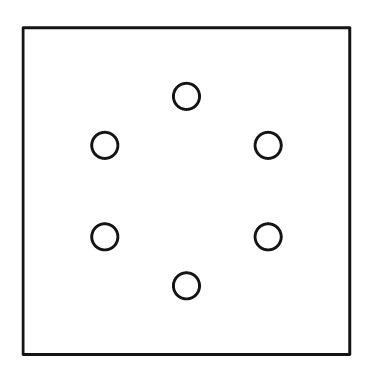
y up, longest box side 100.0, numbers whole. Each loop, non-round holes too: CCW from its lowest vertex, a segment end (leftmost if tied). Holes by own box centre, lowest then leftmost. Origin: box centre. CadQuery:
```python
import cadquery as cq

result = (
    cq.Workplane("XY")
    .moveTo(-50.0, -50.0)
    .lineTo(50.0, -50.0)
    .lineTo(50.0, 50.0)
    .lineTo(-50.0, 50.0)
    .close()
    .moveTo(0.0, -29.0)
    .circle(4.0)
    .moveTo(-25.0, -14.0)
    .circle(4.0)
    .moveTo(25.0, -14.0)
    .circle(4.0)
    .moveTo(-25.0, 14.0)
    .circle(4.0)
    .moveTo(25.0, 14.0)
    .circle(4.0)
    .moveTo(0.0, 29.0)
    .circle(4.0)
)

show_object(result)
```